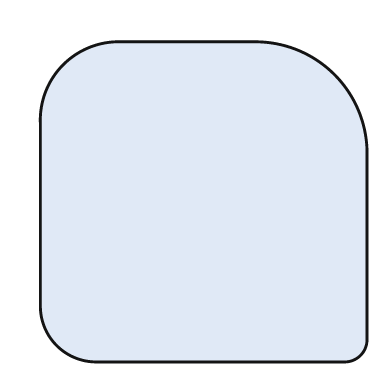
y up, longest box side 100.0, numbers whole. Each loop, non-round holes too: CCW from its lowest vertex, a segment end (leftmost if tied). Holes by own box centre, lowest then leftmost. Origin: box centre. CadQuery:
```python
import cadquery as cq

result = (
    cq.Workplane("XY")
    .moveTo(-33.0, -49.0)
    .lineTo(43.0, -49.0)
    .threePointArc((48.0, -47.0), (50.0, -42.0))
    .lineTo(50.0, 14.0)
    .threePointArc((40.0, 39.0), (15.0, 49.0))
    .lineTo(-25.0, 49.0)
    .threePointArc((-43.0, 42.0), (-50.0, 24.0))
    .lineTo(-50.0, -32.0)
    .threePointArc((-45.0, -44.0), (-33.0, -49.0))
    .close()
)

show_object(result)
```